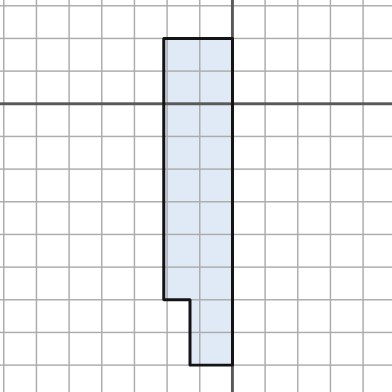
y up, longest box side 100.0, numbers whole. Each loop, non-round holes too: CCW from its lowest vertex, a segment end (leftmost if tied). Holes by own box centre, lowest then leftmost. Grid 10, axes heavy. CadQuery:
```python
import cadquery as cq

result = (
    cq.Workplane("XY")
    .moveTo(-13.0, -80.0)
    .lineTo(0.0, -80.0)
    .lineTo(0.0, 20.0)
    .lineTo(-21.0, 20.0)
    .lineTo(-21.0, -60.0)
    .lineTo(-13.0, -60.0)
    .close()
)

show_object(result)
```